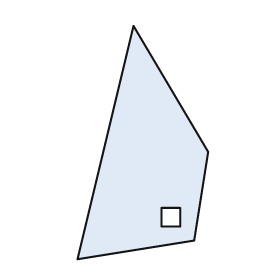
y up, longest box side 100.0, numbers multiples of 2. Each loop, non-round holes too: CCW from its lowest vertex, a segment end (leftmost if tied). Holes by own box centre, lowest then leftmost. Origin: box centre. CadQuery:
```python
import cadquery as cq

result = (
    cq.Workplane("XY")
    .moveTo(-28.0, -50.0)
    .lineTo(22.0, -42.0)
    .lineTo(28.0, -4.0)
    .lineTo(-4.0, 50.0)
    .close()
    .moveTo(8.0, -36.0)
    .lineTo(16.0, -36.0)
    .lineTo(16.0, -28.0)
    .lineTo(8.0, -28.0)
    .close()
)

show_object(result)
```